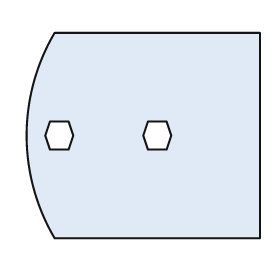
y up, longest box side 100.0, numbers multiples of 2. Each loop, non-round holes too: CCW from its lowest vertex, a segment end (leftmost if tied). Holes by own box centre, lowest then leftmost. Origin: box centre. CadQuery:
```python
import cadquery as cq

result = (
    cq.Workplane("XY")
    .moveTo(-38.0, -44.0)
    .lineTo(50.0, -44.0)
    .lineTo(50.0, 44.0)
    .lineTo(-38.0, 44.0)
    .threePointArc((-50.0, 0.0), (-38.0, -44.0))
    .close()
    .moveTo(-40.0, -6.0)
    .lineTo(-32.0, -6.0)
    .lineTo(-30.0, 0.0)
    .lineTo(-32.0, 6.0)
    .lineTo(-40.0, 6.0)
    .lineTo(-42.0, 0.0)
    .close()
    .moveTo(2.0, -6.0)
    .lineTo(10.0, -6.0)
    .lineTo(12.0, 0.0)
    .lineTo(10.0, 6.0)
    .lineTo(2.0, 6.0)
    .lineTo(0.0, 0.0)
    .close()
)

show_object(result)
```